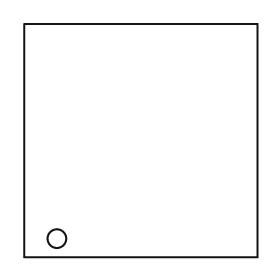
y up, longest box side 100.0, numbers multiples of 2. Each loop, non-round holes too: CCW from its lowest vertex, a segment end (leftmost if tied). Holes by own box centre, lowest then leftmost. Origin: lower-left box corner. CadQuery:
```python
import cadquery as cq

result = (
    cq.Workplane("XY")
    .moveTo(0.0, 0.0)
    .lineTo(100.0, 0.0)
    .lineTo(100.0, 100.0)
    .lineTo(0.0, 100.0)
    .close()
    .moveTo(14.0, 8.0)
    .circle(4.0)
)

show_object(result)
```